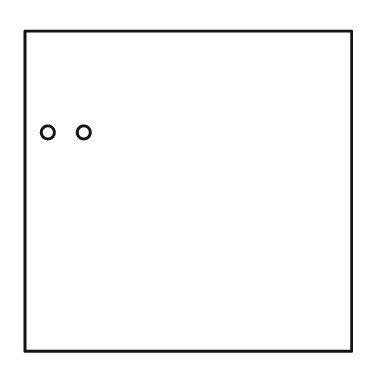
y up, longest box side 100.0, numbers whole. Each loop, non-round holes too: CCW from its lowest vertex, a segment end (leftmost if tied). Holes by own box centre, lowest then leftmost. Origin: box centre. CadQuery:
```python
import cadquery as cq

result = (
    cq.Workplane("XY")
    .moveTo(-50.0, -49.0)
    .lineTo(50.0, -49.0)
    .lineTo(50.0, 49.0)
    .lineTo(-50.0, 49.0)
    .close()
    .moveTo(-43.0, 18.0)
    .circle(2.0)
    .moveTo(-32.0, 18.0)
    .circle(2.0)
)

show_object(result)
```